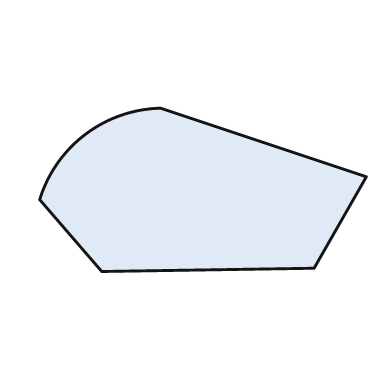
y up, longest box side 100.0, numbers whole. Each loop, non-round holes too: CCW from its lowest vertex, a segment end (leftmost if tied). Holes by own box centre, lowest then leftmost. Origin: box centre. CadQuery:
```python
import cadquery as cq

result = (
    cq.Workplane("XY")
    .moveTo(-31.0, -25.0)
    .lineTo(34.0, -24.0)
    .lineTo(50.0, 4.0)
    .lineTo(-13.0, 25.0)
    .threePointArc((-36.0, 17.0), (-50.0, -3.0))
    .close()
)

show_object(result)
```